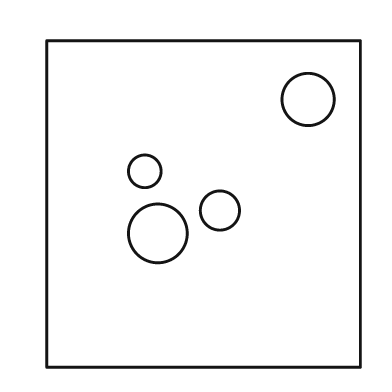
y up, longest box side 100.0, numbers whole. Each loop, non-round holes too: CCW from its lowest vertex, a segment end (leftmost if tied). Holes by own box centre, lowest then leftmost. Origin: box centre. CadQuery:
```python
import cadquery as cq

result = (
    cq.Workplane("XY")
    .moveTo(-48.0, -50.0)
    .lineTo(48.0, -50.0)
    .lineTo(48.0, 50.0)
    .lineTo(-48.0, 50.0)
    .close()
    .moveTo(-14.0, -9.0)
    .circle(9.0)
    .moveTo(5.0, -2.0)
    .circle(6.0)
    .moveTo(-18.0, 10.0)
    .circle(5.0)
    .moveTo(32.0, 32.0)
    .circle(8.0)
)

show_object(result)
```